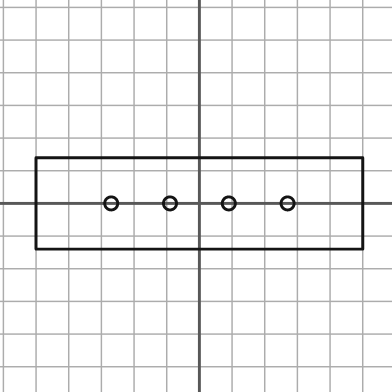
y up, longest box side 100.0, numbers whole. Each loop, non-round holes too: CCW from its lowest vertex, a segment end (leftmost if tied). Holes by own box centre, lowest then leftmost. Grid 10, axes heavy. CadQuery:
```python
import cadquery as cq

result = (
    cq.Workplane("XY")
    .moveTo(-50.0, -14.0)
    .lineTo(50.0, -14.0)
    .lineTo(50.0, 14.0)
    .lineTo(-50.0, 14.0)
    .close()
    .moveTo(-27.0, 0.0)
    .circle(2.0)
    .moveTo(-9.0, 0.0)
    .circle(2.0)
    .moveTo(9.0, 0.0)
    .circle(2.0)
    .moveTo(27.0, 0.0)
    .circle(2.0)
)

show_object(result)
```